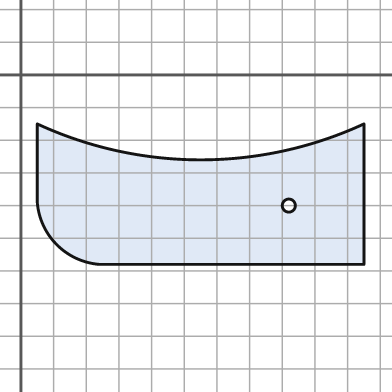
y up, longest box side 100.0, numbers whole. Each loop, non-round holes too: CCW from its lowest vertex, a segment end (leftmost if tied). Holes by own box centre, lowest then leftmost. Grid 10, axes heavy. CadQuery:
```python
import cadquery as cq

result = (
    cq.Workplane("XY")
    .moveTo(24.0, -58.0)
    .lineTo(105.0, -58.0)
    .lineTo(105.0, -15.0)
    .threePointArc((55.0, -26.0), (5.0, -15.0))
    .lineTo(5.0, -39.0)
    .threePointArc((11.0, -52.0), (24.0, -58.0))
    .close()
    .moveTo(82.0, -40.0)
    .circle(2.0)
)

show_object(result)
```